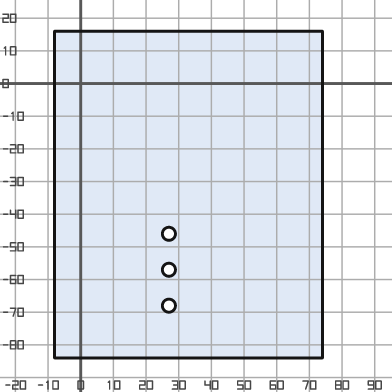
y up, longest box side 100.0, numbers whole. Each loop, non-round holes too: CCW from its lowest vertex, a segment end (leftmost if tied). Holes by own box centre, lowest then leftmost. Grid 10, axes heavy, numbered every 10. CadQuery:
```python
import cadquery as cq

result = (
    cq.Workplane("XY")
    .moveTo(-8.0, -84.0)
    .lineTo(74.0, -84.0)
    .lineTo(74.0, 16.0)
    .lineTo(-8.0, 16.0)
    .close()
    .moveTo(27.0, -68.0)
    .circle(2.0)
    .moveTo(27.0, -57.0)
    .circle(2.0)
    .moveTo(27.0, -46.0)
    .circle(2.0)
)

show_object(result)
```